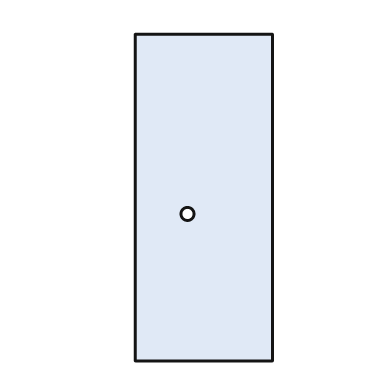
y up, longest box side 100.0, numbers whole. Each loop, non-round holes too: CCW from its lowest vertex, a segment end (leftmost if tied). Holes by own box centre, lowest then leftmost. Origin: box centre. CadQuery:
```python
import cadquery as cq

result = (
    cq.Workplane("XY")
    .moveTo(-21.0, -50.0)
    .lineTo(21.0, -50.0)
    .lineTo(21.0, 50.0)
    .lineTo(-21.0, 50.0)
    .close()
    .moveTo(-5.0, -5.0)
    .circle(2.0)
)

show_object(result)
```